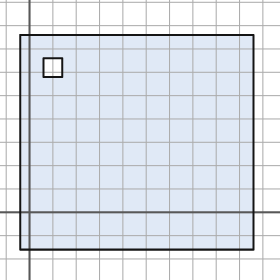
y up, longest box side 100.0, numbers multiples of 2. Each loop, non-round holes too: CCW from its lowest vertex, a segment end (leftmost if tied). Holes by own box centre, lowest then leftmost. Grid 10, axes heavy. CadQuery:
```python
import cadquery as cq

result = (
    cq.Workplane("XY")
    .moveTo(-4.0, -16.0)
    .lineTo(96.0, -16.0)
    .lineTo(96.0, 76.0)
    .lineTo(-4.0, 76.0)
    .close()
    .moveTo(6.0, 58.0)
    .lineTo(14.0, 58.0)
    .lineTo(14.0, 66.0)
    .lineTo(6.0, 66.0)
    .close()
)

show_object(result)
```